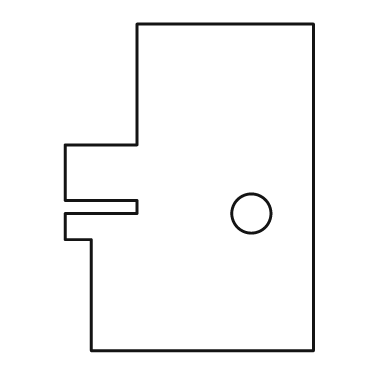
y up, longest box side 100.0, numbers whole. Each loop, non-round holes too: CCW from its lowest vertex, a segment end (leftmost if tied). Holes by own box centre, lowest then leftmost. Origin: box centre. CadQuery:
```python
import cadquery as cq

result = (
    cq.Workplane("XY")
    .moveTo(-30.0, -50.0)
    .lineTo(38.0, -50.0)
    .lineTo(38.0, 50.0)
    .lineTo(-16.0, 50.0)
    .lineTo(-16.0, 13.0)
    .lineTo(-38.0, 13.0)
    .lineTo(-38.0, -4.0)
    .lineTo(-16.0, -4.0)
    .lineTo(-16.0, -8.0)
    .lineTo(-38.0, -8.0)
    .lineTo(-38.0, -16.0)
    .lineTo(-30.0, -16.0)
    .close()
    .moveTo(19.0, -8.0)
    .circle(6.0)
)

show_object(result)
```